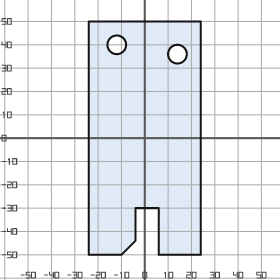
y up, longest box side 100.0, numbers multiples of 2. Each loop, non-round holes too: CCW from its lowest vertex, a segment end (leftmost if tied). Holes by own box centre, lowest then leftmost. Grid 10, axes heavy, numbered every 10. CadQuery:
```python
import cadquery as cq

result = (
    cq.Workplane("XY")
    .moveTo(-24.0, -50.0)
    .lineTo(-10.0, -50.0)
    .lineTo(-4.0, -44.0)
    .lineTo(-4.0, -30.0)
    .lineTo(6.0, -30.0)
    .lineTo(6.0, -50.0)
    .lineTo(24.0, -50.0)
    .lineTo(24.0, 50.0)
    .lineTo(-24.0, 50.0)
    .close()
    .moveTo(14.0, 36.0)
    .circle(4.0)
    .moveTo(-12.0, 40.0)
    .circle(4.0)
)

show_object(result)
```